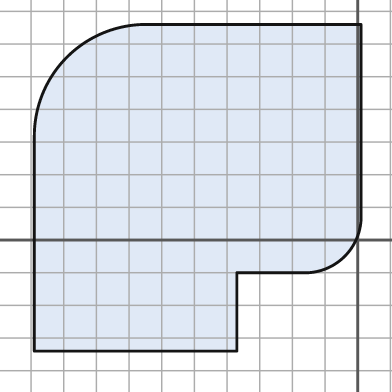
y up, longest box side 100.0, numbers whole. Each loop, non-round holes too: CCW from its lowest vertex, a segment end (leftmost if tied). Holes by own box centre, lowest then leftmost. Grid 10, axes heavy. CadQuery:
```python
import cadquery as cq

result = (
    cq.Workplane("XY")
    .moveTo(-99.0, -34.0)
    .lineTo(-37.0, -34.0)
    .lineTo(-37.0, -10.0)
    .lineTo(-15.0, -10.0)
    .threePointArc((-4.0, -5.0), (1.0, 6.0))
    .lineTo(1.0, 66.0)
    .lineTo(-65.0, 66.0)
    .threePointArc((-89.0, 56.0), (-99.0, 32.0))
    .close()
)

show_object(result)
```